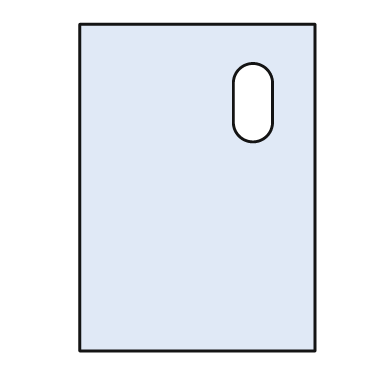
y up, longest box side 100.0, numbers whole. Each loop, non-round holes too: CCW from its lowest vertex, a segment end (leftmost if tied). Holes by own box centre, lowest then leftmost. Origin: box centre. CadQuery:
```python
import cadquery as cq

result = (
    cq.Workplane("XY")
    .moveTo(-36.0, -50.0)
    .lineTo(36.0, -50.0)
    .lineTo(36.0, 50.0)
    .lineTo(-36.0, 50.0)
    .close()
    .moveTo(11.0, 20.0)
    .threePointArc((17.0, 14.0), (23.0, 20.0))
    .lineTo(23.0, 32.0)
    .threePointArc((17.0, 38.0), (11.0, 32.0))
    .close()
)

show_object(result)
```